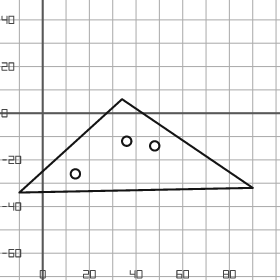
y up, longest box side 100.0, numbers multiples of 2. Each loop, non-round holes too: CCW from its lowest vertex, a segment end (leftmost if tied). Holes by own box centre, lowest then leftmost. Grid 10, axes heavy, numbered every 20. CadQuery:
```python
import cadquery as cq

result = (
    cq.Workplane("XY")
    .moveTo(-10.0, -34.0)
    .lineTo(90.0, -32.0)
    .lineTo(34.0, 6.0)
    .close()
    .moveTo(14.0, -26.0)
    .circle(2.0)
    .moveTo(48.0, -14.0)
    .circle(2.0)
    .moveTo(36.0, -12.0)
    .circle(2.0)
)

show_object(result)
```